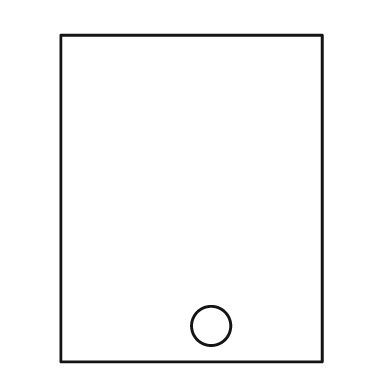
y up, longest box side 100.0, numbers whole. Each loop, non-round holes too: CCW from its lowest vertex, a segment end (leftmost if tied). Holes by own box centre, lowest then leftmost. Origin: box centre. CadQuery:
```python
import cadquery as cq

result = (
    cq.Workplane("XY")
    .moveTo(-40.0, -50.0)
    .lineTo(40.0, -50.0)
    .lineTo(40.0, 50.0)
    .lineTo(-40.0, 50.0)
    .close()
    .moveTo(6.0, -39.0)
    .circle(6.0)
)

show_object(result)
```